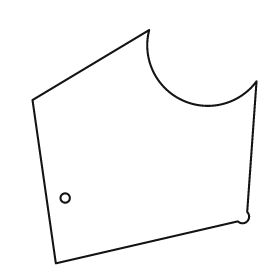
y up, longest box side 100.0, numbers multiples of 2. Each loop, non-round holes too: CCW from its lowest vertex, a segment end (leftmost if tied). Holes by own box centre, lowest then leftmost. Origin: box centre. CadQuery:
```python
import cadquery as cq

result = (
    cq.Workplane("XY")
    .moveTo(-38.0, -50.0)
    .lineTo(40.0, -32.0)
    .threePointArc((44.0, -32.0), (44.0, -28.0))
    .lineTo(48.0, 28.0)
    .threePointArc((16.0, 20.0), (2.0, 50.0))
    .lineTo(-48.0, 20.0)
    .close()
    .moveTo(-34.0, -22.0)
    .circle(2.0)
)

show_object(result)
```